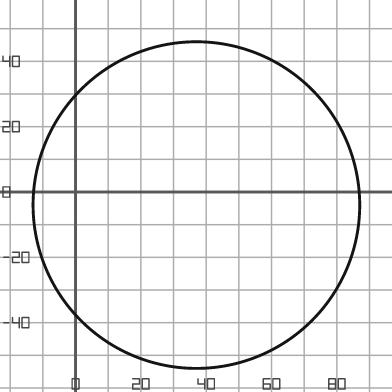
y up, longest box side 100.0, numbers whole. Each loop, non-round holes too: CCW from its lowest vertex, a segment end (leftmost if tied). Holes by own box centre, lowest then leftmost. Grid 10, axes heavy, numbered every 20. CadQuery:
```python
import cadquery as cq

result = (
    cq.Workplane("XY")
    .moveTo(37.0, -4.0)
    .circle(50.0)
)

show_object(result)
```